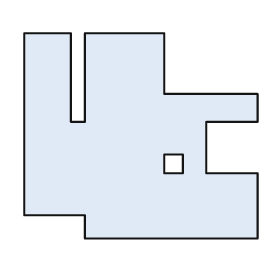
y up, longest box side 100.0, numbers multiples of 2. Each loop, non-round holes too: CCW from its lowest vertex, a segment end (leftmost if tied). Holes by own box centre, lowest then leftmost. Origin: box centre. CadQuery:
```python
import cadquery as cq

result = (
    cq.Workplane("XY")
    .moveTo(-24.0, -44.0)
    .lineTo(50.0, -44.0)
    .lineTo(50.0, -16.0)
    .lineTo(28.0, -16.0)
    .lineTo(28.0, 6.0)
    .lineTo(50.0, 6.0)
    .lineTo(50.0, 18.0)
    .lineTo(10.0, 18.0)
    .lineTo(10.0, 44.0)
    .lineTo(-24.0, 44.0)
    .lineTo(-24.0, 6.0)
    .lineTo(-30.0, 6.0)
    .lineTo(-30.0, 44.0)
    .lineTo(-50.0, 44.0)
    .lineTo(-50.0, -34.0)
    .lineTo(-24.0, -34.0)
    .close()
    .moveTo(10.0, -16.0)
    .lineTo(18.0, -16.0)
    .lineTo(18.0, -8.0)
    .lineTo(10.0, -8.0)
    .close()
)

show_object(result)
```